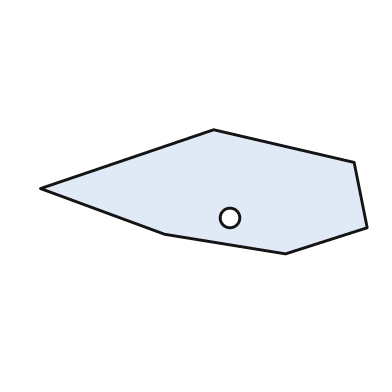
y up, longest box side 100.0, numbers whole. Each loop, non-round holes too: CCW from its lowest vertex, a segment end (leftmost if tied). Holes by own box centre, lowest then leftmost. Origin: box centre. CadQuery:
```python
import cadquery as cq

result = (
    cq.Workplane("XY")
    .moveTo(25.0, -19.0)
    .lineTo(50.0, -11.0)
    .lineTo(46.0, 9.0)
    .lineTo(3.0, 19.0)
    .lineTo(-50.0, 1.0)
    .lineTo(-12.0, -13.0)
    .close()
    .moveTo(8.0, -8.0)
    .circle(3.0)
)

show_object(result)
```